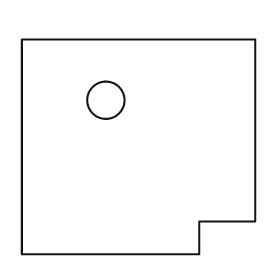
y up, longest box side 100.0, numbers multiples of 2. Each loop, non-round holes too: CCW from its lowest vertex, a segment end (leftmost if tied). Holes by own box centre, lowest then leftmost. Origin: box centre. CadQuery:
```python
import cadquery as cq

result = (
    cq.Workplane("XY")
    .moveTo(-50.0, -46.0)
    .lineTo(26.0, -46.0)
    .lineTo(26.0, -32.0)
    .lineTo(50.0, -32.0)
    .lineTo(50.0, 46.0)
    .lineTo(-50.0, 46.0)
    .close()
    .moveTo(-14.0, 20.0)
    .circle(8.0)
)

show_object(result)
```